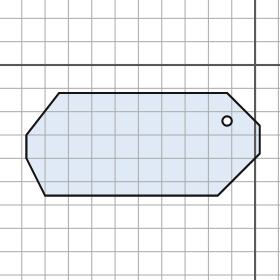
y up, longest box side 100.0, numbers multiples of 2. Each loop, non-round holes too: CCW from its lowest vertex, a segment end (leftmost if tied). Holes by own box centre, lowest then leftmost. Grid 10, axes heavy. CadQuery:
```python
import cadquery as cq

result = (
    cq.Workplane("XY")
    .moveTo(-90.0, -56.0)
    .lineTo(-16.0, -56.0)
    .lineTo(2.0, -38.0)
    .lineTo(2.0, -26.0)
    .lineTo(-12.0, -12.0)
    .lineTo(-84.0, -12.0)
    .lineTo(-98.0, -30.0)
    .lineTo(-98.0, -40.0)
    .close()
    .moveTo(-12.0, -24.0)
    .circle(2.0)
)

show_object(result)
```